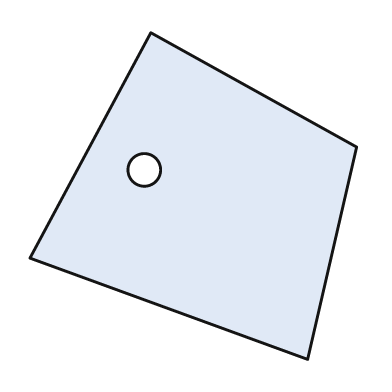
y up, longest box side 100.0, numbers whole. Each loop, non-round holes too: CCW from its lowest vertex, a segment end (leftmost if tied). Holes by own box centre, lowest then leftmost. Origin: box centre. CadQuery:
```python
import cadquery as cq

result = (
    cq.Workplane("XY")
    .moveTo(35.0, -50.0)
    .lineTo(50.0, 15.0)
    .lineTo(-13.0, 50.0)
    .lineTo(-50.0, -19.0)
    .close()
    .moveTo(-15.0, 8.0)
    .circle(5.0)
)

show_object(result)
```